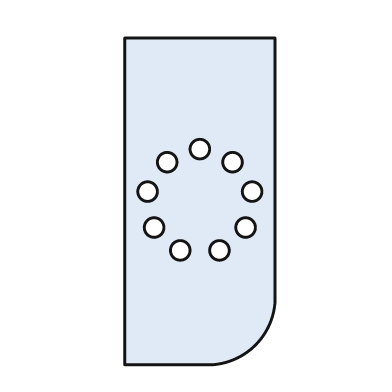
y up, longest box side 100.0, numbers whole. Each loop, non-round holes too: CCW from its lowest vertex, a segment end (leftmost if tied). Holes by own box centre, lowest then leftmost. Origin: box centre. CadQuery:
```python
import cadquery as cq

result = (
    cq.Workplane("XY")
    .moveTo(-23.0, -50.0)
    .lineTo(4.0, -50.0)
    .threePointArc((17.0, -44.0), (23.0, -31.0))
    .lineTo(23.0, 50.0)
    .lineTo(-23.0, 50.0)
    .close()
    .moveTo(-6.0, -15.0)
    .circle(3.0)
    .moveTo(6.0, -15.0)
    .circle(3.0)
    .moveTo(-14.0, -8.0)
    .circle(3.0)
    .moveTo(14.0, -8.0)
    .circle(3.0)
    .moveTo(-16.0, 3.0)
    .circle(3.0)
    .moveTo(16.0, 3.0)
    .circle(3.0)
    .moveTo(-10.0, 12.0)
    .circle(3.0)
    .moveTo(10.0, 12.0)
    .circle(3.0)
    .moveTo(0.0, 16.0)
    .circle(3.0)
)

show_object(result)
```